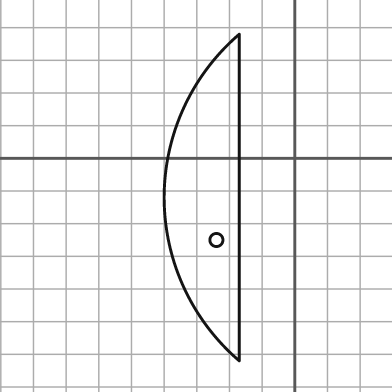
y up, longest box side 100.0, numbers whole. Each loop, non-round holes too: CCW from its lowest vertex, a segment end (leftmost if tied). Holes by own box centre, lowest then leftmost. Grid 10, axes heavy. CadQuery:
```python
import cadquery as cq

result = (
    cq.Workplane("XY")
    .moveTo(-17.0, -62.0)
    .lineTo(-17.0, 38.0)
    .threePointArc((-40.0, -12.0), (-17.0, -62.0))
    .close()
    .moveTo(-24.0, -25.0)
    .circle(2.0)
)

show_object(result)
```